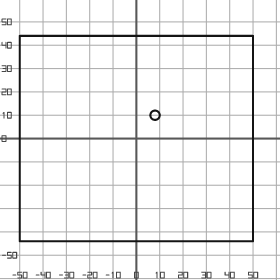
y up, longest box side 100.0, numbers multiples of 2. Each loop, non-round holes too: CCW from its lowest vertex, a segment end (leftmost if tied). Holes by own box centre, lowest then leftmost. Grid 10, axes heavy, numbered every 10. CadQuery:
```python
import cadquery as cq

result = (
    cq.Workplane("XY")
    .moveTo(-50.0, -44.0)
    .lineTo(50.0, -44.0)
    .lineTo(50.0, 44.0)
    .lineTo(-50.0, 44.0)
    .close()
    .moveTo(8.0, 10.0)
    .circle(2.0)
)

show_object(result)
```